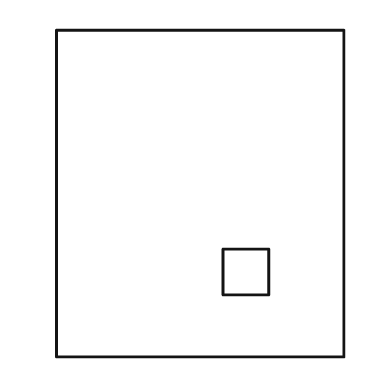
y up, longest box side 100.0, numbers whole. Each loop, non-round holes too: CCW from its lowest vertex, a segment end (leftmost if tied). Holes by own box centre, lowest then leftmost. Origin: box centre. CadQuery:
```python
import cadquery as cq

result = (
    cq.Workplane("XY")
    .moveTo(-44.0, -50.0)
    .lineTo(44.0, -50.0)
    .lineTo(44.0, 50.0)
    .lineTo(-44.0, 50.0)
    .close()
    .moveTo(7.0, -31.0)
    .lineTo(21.0, -31.0)
    .lineTo(21.0, -17.0)
    .lineTo(7.0, -17.0)
    .close()
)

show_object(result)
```